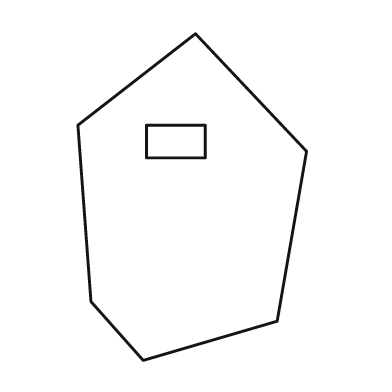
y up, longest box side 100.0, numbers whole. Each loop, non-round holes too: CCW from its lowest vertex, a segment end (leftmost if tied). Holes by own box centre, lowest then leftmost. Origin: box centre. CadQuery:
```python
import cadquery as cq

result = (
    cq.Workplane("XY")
    .moveTo(-15.0, -50.0)
    .lineTo(26.0, -38.0)
    .lineTo(35.0, 14.0)
    .lineTo(1.0, 50.0)
    .lineTo(-35.0, 22.0)
    .lineTo(-31.0, -32.0)
    .close()
    .moveTo(-14.0, 12.0)
    .lineTo(4.0, 12.0)
    .lineTo(4.0, 22.0)
    .lineTo(-14.0, 22.0)
    .close()
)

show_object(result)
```